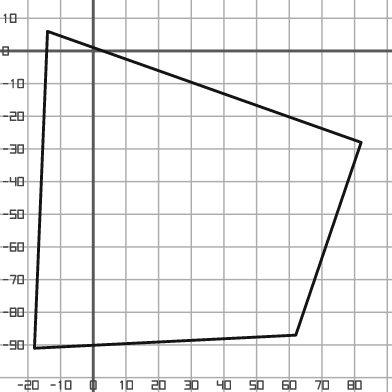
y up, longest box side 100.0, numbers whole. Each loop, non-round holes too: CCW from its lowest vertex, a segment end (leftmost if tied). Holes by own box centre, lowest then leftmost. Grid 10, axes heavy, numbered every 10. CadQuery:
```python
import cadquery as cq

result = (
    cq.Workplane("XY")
    .moveTo(-18.0, -91.0)
    .lineTo(62.0, -87.0)
    .lineTo(82.0, -28.0)
    .lineTo(-14.0, 6.0)
    .close()
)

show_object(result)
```